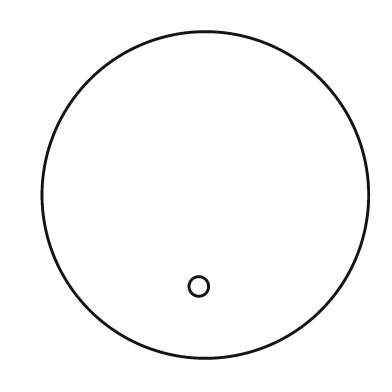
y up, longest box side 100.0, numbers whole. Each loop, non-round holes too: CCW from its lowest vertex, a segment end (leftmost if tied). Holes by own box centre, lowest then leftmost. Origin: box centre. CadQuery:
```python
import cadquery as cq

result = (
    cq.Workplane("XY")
    .moveTo(0.0, 0.0)
    .circle(50.0)
    .moveTo(-2.0, -28.0)
    .circle(3.0)
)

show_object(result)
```